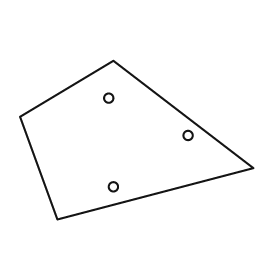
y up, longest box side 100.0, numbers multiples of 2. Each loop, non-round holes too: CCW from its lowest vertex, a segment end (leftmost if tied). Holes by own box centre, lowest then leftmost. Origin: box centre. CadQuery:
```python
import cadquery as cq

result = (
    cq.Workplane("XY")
    .moveTo(-34.0, -34.0)
    .lineTo(50.0, -12.0)
    .lineTo(-10.0, 34.0)
    .lineTo(-50.0, 10.0)
    .close()
    .moveTo(-10.0, -20.0)
    .circle(2.0)
    .moveTo(22.0, 2.0)
    .circle(2.0)
    .moveTo(-12.0, 18.0)
    .circle(2.0)
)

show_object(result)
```